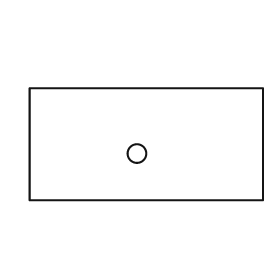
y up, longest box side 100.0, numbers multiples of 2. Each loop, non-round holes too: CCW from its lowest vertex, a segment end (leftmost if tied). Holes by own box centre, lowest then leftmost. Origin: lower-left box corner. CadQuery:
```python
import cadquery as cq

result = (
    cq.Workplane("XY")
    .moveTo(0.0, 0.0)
    .lineTo(100.0, 0.0)
    .lineTo(100.0, 48.0)
    .lineTo(0.0, 48.0)
    .close()
    .moveTo(46.0, 20.0)
    .circle(4.0)
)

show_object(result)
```